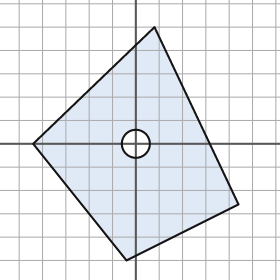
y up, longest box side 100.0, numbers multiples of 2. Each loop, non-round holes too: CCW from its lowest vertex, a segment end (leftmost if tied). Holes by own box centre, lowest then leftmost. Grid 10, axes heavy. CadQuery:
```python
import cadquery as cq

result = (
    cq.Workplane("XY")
    .moveTo(-4.0, -50.0)
    .lineTo(44.0, -26.0)
    .lineTo(8.0, 50.0)
    .lineTo(-44.0, 0.0)
    .close()
    .moveTo(0.0, 0.0)
    .circle(6.0)
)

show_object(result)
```